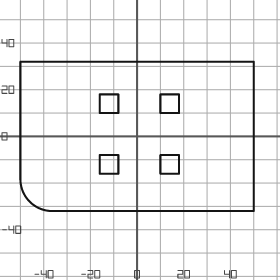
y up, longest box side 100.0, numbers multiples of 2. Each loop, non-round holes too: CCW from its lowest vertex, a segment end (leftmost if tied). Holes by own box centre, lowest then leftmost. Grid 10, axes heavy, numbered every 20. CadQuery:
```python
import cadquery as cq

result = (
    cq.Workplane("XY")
    .moveTo(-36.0, -32.0)
    .lineTo(50.0, -32.0)
    .lineTo(50.0, 32.0)
    .lineTo(-50.0, 32.0)
    .lineTo(-50.0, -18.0)
    .threePointArc((-46.0, -28.0), (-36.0, -32.0))
    .close()
    .moveTo(-16.0, -16.0)
    .lineTo(-8.0, -16.0)
    .lineTo(-8.0, -8.0)
    .lineTo(-16.0, -8.0)
    .close()
    .moveTo(10.0, -16.0)
    .lineTo(18.0, -16.0)
    .lineTo(18.0, -8.0)
    .lineTo(10.0, -8.0)
    .close()
    .moveTo(-16.0, 10.0)
    .lineTo(-8.0, 10.0)
    .lineTo(-8.0, 18.0)
    .lineTo(-16.0, 18.0)
    .close()
    .moveTo(10.0, 10.0)
    .lineTo(18.0, 10.0)
    .lineTo(18.0, 18.0)
    .lineTo(10.0, 18.0)
    .close()
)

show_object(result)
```